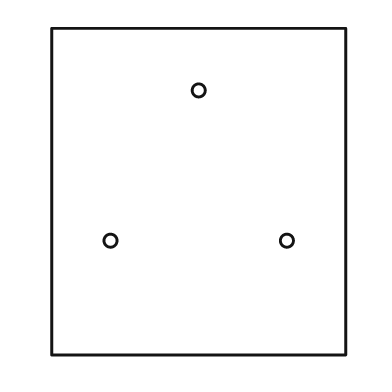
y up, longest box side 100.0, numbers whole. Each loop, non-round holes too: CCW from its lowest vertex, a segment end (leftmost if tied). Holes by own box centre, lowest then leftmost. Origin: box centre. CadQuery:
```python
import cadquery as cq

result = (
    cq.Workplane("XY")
    .moveTo(-45.0, -50.0)
    .lineTo(45.0, -50.0)
    .lineTo(45.0, 50.0)
    .lineTo(-45.0, 50.0)
    .close()
    .moveTo(-27.0, -15.0)
    .circle(2.0)
    .moveTo(27.0, -15.0)
    .circle(2.0)
    .moveTo(0.0, 31.0)
    .circle(2.0)
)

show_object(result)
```